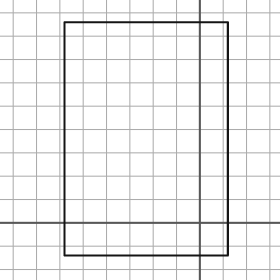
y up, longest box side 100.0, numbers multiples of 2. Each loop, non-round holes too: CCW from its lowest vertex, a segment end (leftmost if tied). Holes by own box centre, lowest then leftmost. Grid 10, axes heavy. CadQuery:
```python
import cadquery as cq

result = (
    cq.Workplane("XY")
    .moveTo(-58.0, -14.0)
    .lineTo(12.0, -14.0)
    .lineTo(12.0, 86.0)
    .lineTo(-58.0, 86.0)
    .close()
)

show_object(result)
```